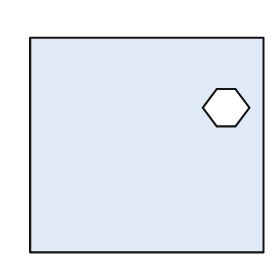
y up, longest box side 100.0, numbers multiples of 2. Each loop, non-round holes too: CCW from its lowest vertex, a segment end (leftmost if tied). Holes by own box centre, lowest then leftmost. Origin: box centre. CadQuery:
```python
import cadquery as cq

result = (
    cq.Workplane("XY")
    .moveTo(-50.0, -46.0)
    .lineTo(50.0, -46.0)
    .lineTo(50.0, 46.0)
    .lineTo(-50.0, 46.0)
    .close()
    .moveTo(30.0, 8.0)
    .lineTo(38.0, 8.0)
    .lineTo(44.0, 16.0)
    .lineTo(38.0, 24.0)
    .lineTo(30.0, 24.0)
    .lineTo(24.0, 16.0)
    .close()
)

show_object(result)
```